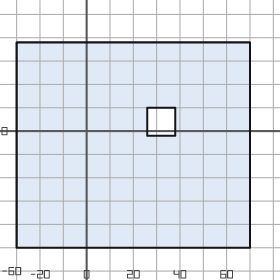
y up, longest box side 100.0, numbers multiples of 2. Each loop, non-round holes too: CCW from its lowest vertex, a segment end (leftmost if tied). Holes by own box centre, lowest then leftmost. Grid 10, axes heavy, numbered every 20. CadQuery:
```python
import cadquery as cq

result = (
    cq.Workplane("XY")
    .moveTo(-30.0, -50.0)
    .lineTo(70.0, -50.0)
    .lineTo(70.0, 38.0)
    .lineTo(-30.0, 38.0)
    .close()
    .moveTo(26.0, -2.0)
    .lineTo(38.0, -2.0)
    .lineTo(38.0, 10.0)
    .lineTo(26.0, 10.0)
    .close()
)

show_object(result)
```